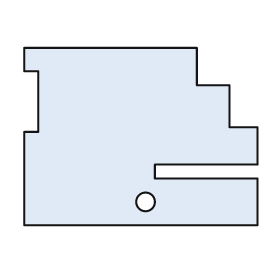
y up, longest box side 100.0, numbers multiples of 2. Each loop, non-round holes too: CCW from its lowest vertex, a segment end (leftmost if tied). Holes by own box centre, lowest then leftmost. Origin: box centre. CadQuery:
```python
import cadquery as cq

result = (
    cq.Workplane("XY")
    .moveTo(-50.0, -38.0)
    .lineTo(50.0, -38.0)
    .lineTo(50.0, -18.0)
    .lineTo(6.0, -18.0)
    .lineTo(6.0, -12.0)
    .lineTo(50.0, -12.0)
    .lineTo(50.0, 4.0)
    .lineTo(38.0, 4.0)
    .lineTo(38.0, 22.0)
    .lineTo(24.0, 22.0)
    .lineTo(24.0, 38.0)
    .lineTo(-50.0, 38.0)
    .lineTo(-50.0, 28.0)
    .lineTo(-44.0, 28.0)
    .lineTo(-44.0, 2.0)
    .lineTo(-50.0, 2.0)
    .close()
    .moveTo(2.0, -28.0)
    .circle(4.0)
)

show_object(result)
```